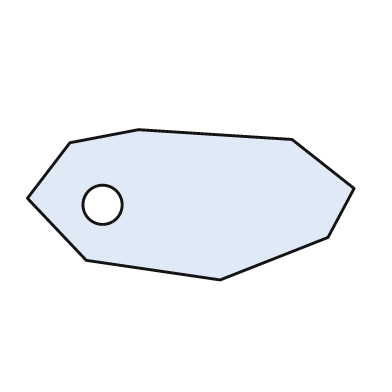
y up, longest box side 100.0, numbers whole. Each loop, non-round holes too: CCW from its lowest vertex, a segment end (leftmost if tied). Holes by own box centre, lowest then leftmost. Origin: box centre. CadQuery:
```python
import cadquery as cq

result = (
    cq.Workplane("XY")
    .moveTo(9.0, -23.0)
    .lineTo(42.0, -10.0)
    .lineTo(50.0, 5.0)
    .lineTo(31.0, 20.0)
    .lineTo(-16.0, 23.0)
    .lineTo(-37.0, 19.0)
    .lineTo(-50.0, 2.0)
    .lineTo(-32.0, -17.0)
    .close()
    .moveTo(-27.0, 0.0)
    .circle(6.0)
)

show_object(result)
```